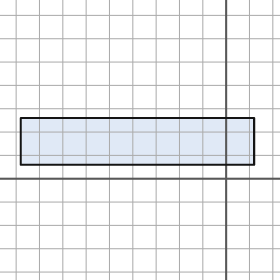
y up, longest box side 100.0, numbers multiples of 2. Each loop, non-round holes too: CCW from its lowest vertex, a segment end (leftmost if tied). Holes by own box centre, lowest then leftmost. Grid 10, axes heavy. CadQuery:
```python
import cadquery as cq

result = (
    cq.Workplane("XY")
    .moveTo(-88.0, 6.0)
    .lineTo(12.0, 6.0)
    .lineTo(12.0, 26.0)
    .lineTo(-88.0, 26.0)
    .close()
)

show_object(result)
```